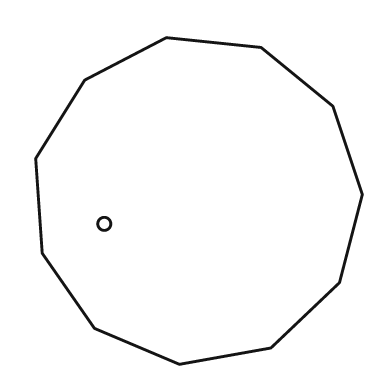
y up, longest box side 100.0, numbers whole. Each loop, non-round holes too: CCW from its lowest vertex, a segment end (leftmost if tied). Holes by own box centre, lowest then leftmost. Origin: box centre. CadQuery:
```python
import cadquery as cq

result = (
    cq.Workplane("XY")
    .moveTo(-6.0, -50.0)
    .lineTo(22.0, -45.0)
    .lineTo(43.0, -25.0)
    .lineTo(50.0, 2.0)
    .lineTo(41.0, 29.0)
    .lineTo(19.0, 47.0)
    .lineTo(-10.0, 50.0)
    .lineTo(-35.0, 37.0)
    .lineTo(-50.0, 13.0)
    .lineTo(-48.0, -16.0)
    .lineTo(-32.0, -39.0)
    .close()
    .moveTo(-29.0, -7.0)
    .circle(2.0)
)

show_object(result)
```